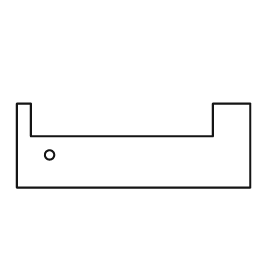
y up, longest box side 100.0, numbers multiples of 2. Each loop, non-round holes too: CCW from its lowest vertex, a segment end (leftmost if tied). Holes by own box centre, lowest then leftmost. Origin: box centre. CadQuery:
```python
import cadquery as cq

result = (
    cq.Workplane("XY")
    .moveTo(-50.0, -18.0)
    .lineTo(50.0, -18.0)
    .lineTo(50.0, 18.0)
    .lineTo(34.0, 18.0)
    .lineTo(34.0, 4.0)
    .lineTo(-44.0, 4.0)
    .lineTo(-44.0, 18.0)
    .lineTo(-50.0, 18.0)
    .close()
    .moveTo(-36.0, -4.0)
    .circle(2.0)
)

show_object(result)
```